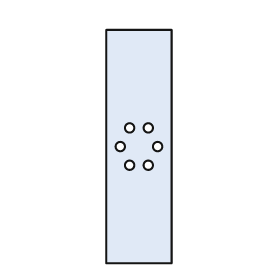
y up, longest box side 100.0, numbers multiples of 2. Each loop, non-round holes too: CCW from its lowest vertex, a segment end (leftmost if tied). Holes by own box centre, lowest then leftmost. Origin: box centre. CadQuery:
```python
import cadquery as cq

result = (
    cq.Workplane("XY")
    .moveTo(-14.0, -50.0)
    .lineTo(14.0, -50.0)
    .lineTo(14.0, 50.0)
    .lineTo(-14.0, 50.0)
    .close()
    .moveTo(-4.0, -8.0)
    .circle(2.0)
    .moveTo(4.0, -8.0)
    .circle(2.0)
    .moveTo(-8.0, 0.0)
    .circle(2.0)
    .moveTo(8.0, 0.0)
    .circle(2.0)
    .moveTo(-4.0, 8.0)
    .circle(2.0)
    .moveTo(4.0, 8.0)
    .circle(2.0)
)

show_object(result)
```